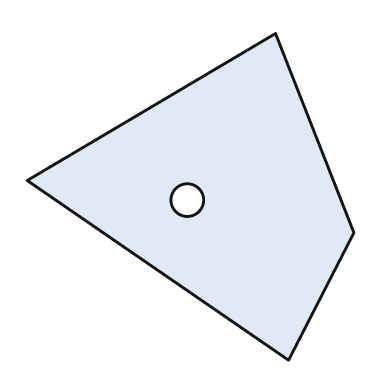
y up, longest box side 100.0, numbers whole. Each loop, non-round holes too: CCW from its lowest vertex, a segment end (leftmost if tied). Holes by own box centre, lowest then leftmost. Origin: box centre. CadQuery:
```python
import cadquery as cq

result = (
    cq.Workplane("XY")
    .moveTo(30.0, -50.0)
    .lineTo(50.0, -11.0)
    .lineTo(26.0, 50.0)
    .lineTo(-50.0, 5.0)
    .close()
    .moveTo(-1.0, -1.0)
    .circle(5.0)
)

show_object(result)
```